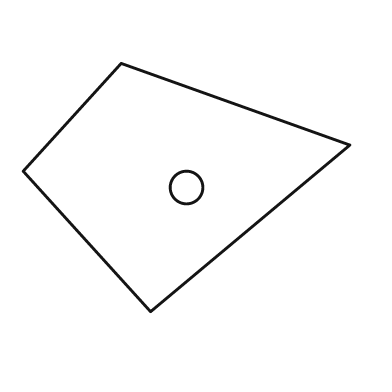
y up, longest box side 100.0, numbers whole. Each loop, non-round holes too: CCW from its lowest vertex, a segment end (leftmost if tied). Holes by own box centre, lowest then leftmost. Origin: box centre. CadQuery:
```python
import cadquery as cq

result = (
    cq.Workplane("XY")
    .moveTo(-11.0, -38.0)
    .lineTo(50.0, 13.0)
    .lineTo(-20.0, 38.0)
    .lineTo(-50.0, 5.0)
    .close()
    .moveTo(0.0, 0.0)
    .circle(5.0)
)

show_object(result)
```